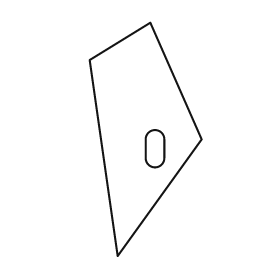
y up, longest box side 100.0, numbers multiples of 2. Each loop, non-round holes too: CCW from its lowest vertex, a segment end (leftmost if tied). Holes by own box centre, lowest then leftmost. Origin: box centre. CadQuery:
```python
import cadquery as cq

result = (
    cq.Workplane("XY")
    .moveTo(-12.0, -50.0)
    .lineTo(24.0, 0.0)
    .lineTo(2.0, 50.0)
    .lineTo(-24.0, 34.0)
    .close()
    .moveTo(0.0, -8.0)
    .threePointArc((4.0, -12.0), (8.0, -8.0))
    .lineTo(8.0, 0.0)
    .threePointArc((4.0, 4.0), (0.0, 0.0))
    .close()
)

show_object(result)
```